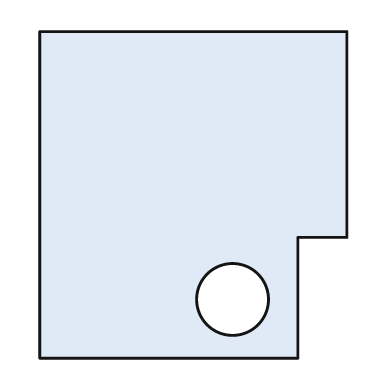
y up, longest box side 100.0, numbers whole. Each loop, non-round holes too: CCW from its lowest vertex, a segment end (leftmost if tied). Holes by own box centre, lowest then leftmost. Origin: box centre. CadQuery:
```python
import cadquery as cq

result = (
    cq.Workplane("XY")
    .moveTo(-47.0, -50.0)
    .lineTo(32.0, -50.0)
    .lineTo(32.0, -13.0)
    .lineTo(47.0, -13.0)
    .lineTo(47.0, 50.0)
    .lineTo(-47.0, 50.0)
    .close()
    .moveTo(12.0, -32.0)
    .circle(11.0)
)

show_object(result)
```